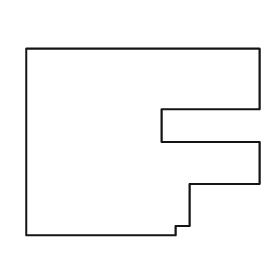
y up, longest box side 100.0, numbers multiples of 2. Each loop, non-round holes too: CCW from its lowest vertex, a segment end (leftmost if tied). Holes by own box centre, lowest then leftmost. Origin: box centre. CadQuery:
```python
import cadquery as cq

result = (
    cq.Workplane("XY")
    .moveTo(-50.0, -40.0)
    .lineTo(14.0, -40.0)
    .lineTo(14.0, -36.0)
    .lineTo(20.0, -36.0)
    .lineTo(20.0, -18.0)
    .lineTo(50.0, -18.0)
    .lineTo(50.0, 0.0)
    .lineTo(8.0, 0.0)
    .lineTo(8.0, 14.0)
    .lineTo(50.0, 14.0)
    .lineTo(50.0, 40.0)
    .lineTo(-50.0, 40.0)
    .close()
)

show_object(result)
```